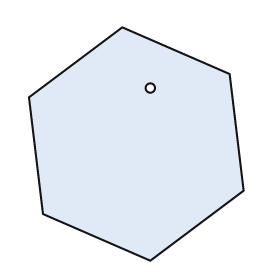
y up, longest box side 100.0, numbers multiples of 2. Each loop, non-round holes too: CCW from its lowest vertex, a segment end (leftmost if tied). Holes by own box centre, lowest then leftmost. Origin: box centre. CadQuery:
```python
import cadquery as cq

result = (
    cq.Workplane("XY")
    .moveTo(6.0, -50.0)
    .lineTo(46.0, -20.0)
    .lineTo(40.0, 30.0)
    .lineTo(-6.0, 50.0)
    .lineTo(-46.0, 20.0)
    .lineTo(-40.0, -30.0)
    .close()
    .moveTo(6.0, 24.0)
    .circle(2.0)
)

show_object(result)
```